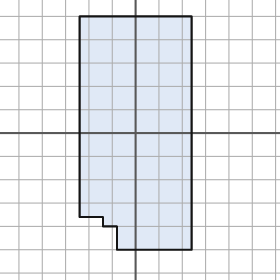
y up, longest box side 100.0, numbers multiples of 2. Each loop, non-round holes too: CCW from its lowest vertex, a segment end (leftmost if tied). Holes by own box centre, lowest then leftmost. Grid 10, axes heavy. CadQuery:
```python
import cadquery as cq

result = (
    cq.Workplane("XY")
    .moveTo(-8.0, -50.0)
    .lineTo(24.0, -50.0)
    .lineTo(24.0, 50.0)
    .lineTo(-24.0, 50.0)
    .lineTo(-24.0, -36.0)
    .lineTo(-14.0, -36.0)
    .lineTo(-14.0, -40.0)
    .lineTo(-8.0, -40.0)
    .close()
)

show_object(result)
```